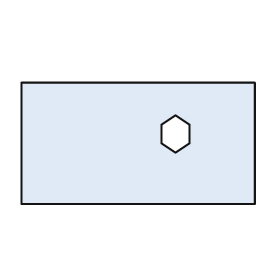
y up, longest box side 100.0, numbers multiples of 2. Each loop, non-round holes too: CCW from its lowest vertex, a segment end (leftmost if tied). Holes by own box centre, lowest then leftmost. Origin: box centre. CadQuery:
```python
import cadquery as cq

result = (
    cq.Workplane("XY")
    .moveTo(-50.0, -26.0)
    .lineTo(50.0, -26.0)
    .lineTo(50.0, 26.0)
    .lineTo(-50.0, 26.0)
    .close()
    .moveTo(16.0, -4.0)
    .lineTo(22.0, 0.0)
    .lineTo(22.0, 8.0)
    .lineTo(16.0, 12.0)
    .lineTo(10.0, 8.0)
    .lineTo(10.0, 0.0)
    .close()
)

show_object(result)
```